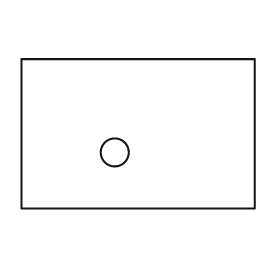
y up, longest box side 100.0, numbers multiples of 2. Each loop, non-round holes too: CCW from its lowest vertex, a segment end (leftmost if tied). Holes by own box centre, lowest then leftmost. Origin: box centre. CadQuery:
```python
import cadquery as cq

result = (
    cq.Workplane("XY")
    .moveTo(-50.0, -32.0)
    .lineTo(50.0, -32.0)
    .lineTo(50.0, 32.0)
    .lineTo(-50.0, 32.0)
    .close()
    .moveTo(-10.0, -8.0)
    .circle(6.0)
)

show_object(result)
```